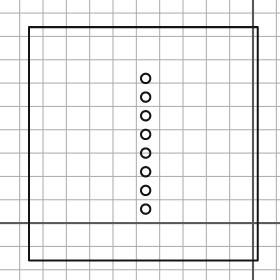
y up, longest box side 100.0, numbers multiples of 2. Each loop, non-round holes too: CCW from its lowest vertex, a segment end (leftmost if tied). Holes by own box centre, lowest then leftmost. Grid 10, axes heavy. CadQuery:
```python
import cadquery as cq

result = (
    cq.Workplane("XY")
    .moveTo(-96.0, -16.0)
    .lineTo(2.0, -16.0)
    .lineTo(2.0, 84.0)
    .lineTo(-96.0, 84.0)
    .close()
    .moveTo(-46.0, 6.0)
    .circle(2.0)
    .moveTo(-46.0, 14.0)
    .circle(2.0)
    .moveTo(-46.0, 22.0)
    .circle(2.0)
    .moveTo(-46.0, 30.0)
    .circle(2.0)
    .moveTo(-46.0, 38.0)
    .circle(2.0)
    .moveTo(-46.0, 46.0)
    .circle(2.0)
    .moveTo(-46.0, 54.0)
    .circle(2.0)
    .moveTo(-46.0, 62.0)
    .circle(2.0)
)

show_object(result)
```